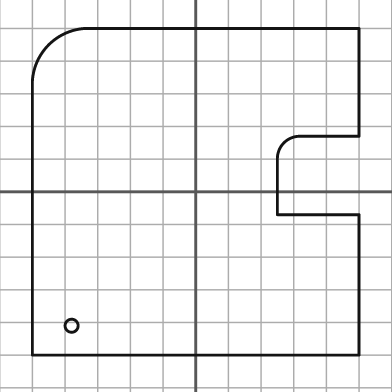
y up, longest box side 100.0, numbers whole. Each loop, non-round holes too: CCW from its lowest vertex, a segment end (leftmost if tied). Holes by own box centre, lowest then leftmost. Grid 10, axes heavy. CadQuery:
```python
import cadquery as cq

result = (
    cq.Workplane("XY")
    .moveTo(-50.0, -50.0)
    .lineTo(50.0, -50.0)
    .lineTo(50.0, -7.0)
    .lineTo(25.0, -7.0)
    .lineTo(25.0, 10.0)
    .threePointArc((27.0, 15.0), (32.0, 17.0))
    .lineTo(50.0, 17.0)
    .lineTo(50.0, 50.0)
    .lineTo(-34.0, 50.0)
    .threePointArc((-45.0, 45.0), (-50.0, 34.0))
    .close()
    .moveTo(-38.0, -41.0)
    .circle(2.0)
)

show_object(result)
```